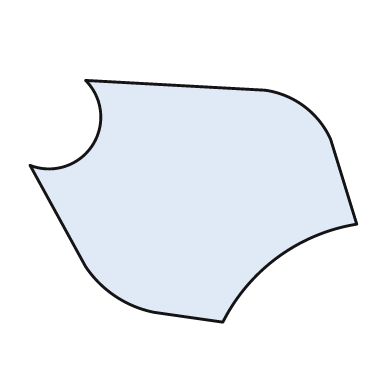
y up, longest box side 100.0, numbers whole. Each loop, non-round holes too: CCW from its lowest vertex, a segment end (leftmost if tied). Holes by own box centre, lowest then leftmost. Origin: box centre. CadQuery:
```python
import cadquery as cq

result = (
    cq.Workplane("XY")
    .moveTo(9.0, -37.0)
    .threePointArc((26.0, -17.0), (50.0, -7.0))
    .lineTo(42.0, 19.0)
    .threePointArc((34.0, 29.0), (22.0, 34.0))
    .lineTo(-33.0, 37.0)
    .threePointArc((-31.0, 17.0), (-50.0, 11.0))
    .lineTo(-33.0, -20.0)
    .threePointArc((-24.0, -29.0), (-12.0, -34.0))
    .close()
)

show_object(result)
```